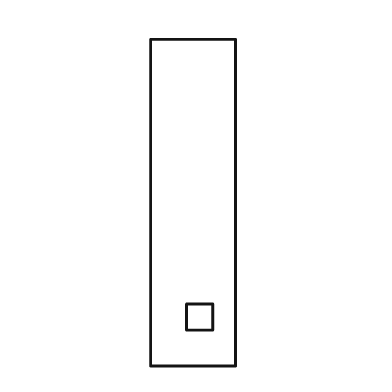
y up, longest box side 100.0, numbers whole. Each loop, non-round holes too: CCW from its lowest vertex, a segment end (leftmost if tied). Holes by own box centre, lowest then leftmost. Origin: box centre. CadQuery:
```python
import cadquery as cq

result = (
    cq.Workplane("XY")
    .moveTo(-13.0, -50.0)
    .lineTo(13.0, -50.0)
    .lineTo(13.0, 50.0)
    .lineTo(-13.0, 50.0)
    .close()
    .moveTo(-2.0, -39.0)
    .lineTo(6.0, -39.0)
    .lineTo(6.0, -31.0)
    .lineTo(-2.0, -31.0)
    .close()
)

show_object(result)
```